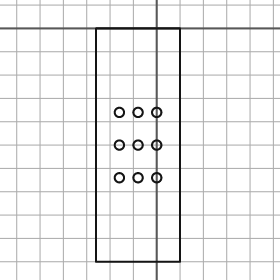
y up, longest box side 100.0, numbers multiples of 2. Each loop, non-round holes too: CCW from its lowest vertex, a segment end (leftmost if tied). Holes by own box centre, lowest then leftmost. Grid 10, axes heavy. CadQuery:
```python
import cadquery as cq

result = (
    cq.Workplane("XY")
    .moveTo(-26.0, -100.0)
    .lineTo(10.0, -100.0)
    .lineTo(10.0, 0.0)
    .lineTo(-26.0, 0.0)
    .close()
    .moveTo(-16.0, -64.0)
    .circle(2.0)
    .moveTo(-8.0, -64.0)
    .circle(2.0)
    .moveTo(0.0, -64.0)
    .circle(2.0)
    .moveTo(-16.0, -50.0)
    .circle(2.0)
    .moveTo(-8.0, -50.0)
    .circle(2.0)
    .moveTo(0.0, -50.0)
    .circle(2.0)
    .moveTo(-16.0, -36.0)
    .circle(2.0)
    .moveTo(-8.0, -36.0)
    .circle(2.0)
    .moveTo(0.0, -36.0)
    .circle(2.0)
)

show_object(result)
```